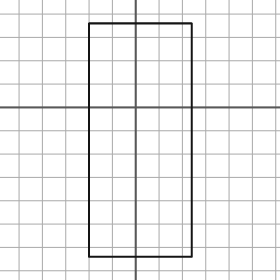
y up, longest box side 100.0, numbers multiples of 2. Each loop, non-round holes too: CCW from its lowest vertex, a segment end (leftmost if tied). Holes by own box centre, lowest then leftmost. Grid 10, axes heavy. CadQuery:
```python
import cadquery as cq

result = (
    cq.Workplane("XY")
    .moveTo(-20.0, -64.0)
    .lineTo(24.0, -64.0)
    .lineTo(24.0, 36.0)
    .lineTo(-20.0, 36.0)
    .close()
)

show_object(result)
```